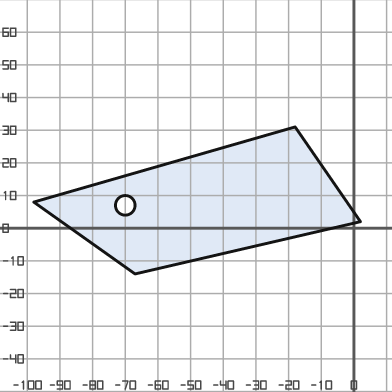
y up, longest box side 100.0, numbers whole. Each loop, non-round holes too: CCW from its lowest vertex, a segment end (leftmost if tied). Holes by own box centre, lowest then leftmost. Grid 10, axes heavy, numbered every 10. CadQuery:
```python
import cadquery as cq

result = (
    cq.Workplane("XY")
    .moveTo(-67.0, -14.0)
    .lineTo(2.0, 2.0)
    .lineTo(-18.0, 31.0)
    .lineTo(-98.0, 8.0)
    .close()
    .moveTo(-70.0, 7.0)
    .circle(3.0)
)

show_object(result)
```